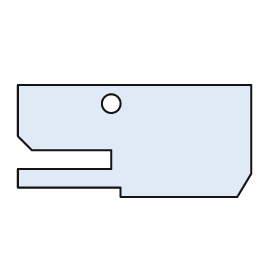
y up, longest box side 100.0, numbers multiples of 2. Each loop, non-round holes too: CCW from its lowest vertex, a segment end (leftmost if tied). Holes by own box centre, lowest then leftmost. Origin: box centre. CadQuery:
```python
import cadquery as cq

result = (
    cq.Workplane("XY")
    .moveTo(-6.0, -24.0)
    .lineTo(44.0, -24.0)
    .lineTo(50.0, -14.0)
    .lineTo(50.0, 24.0)
    .lineTo(-50.0, 24.0)
    .lineTo(-50.0, 2.0)
    .lineTo(-44.0, -4.0)
    .lineTo(-10.0, -4.0)
    .lineTo(-10.0, -12.0)
    .lineTo(-50.0, -12.0)
    .lineTo(-50.0, -20.0)
    .lineTo(-6.0, -20.0)
    .close()
    .moveTo(-10.0, 16.0)
    .circle(4.0)
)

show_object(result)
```